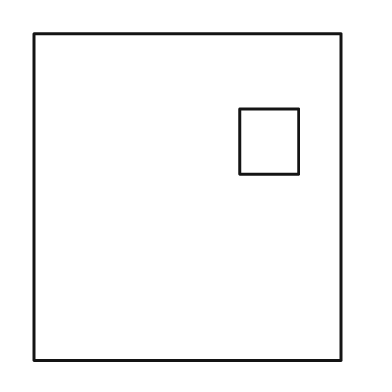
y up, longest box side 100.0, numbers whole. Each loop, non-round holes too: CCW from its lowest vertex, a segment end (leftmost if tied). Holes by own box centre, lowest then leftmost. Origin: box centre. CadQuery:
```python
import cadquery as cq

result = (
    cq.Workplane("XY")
    .moveTo(-47.0, -50.0)
    .lineTo(47.0, -50.0)
    .lineTo(47.0, 50.0)
    .lineTo(-47.0, 50.0)
    .close()
    .moveTo(16.0, 7.0)
    .lineTo(34.0, 7.0)
    .lineTo(34.0, 27.0)
    .lineTo(16.0, 27.0)
    .close()
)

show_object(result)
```